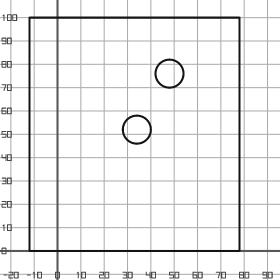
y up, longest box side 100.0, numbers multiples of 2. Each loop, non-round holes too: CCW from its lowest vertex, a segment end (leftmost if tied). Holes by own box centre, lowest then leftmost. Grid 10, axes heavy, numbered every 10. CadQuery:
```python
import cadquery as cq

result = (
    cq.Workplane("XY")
    .moveTo(-12.0, 0.0)
    .lineTo(78.0, 0.0)
    .lineTo(78.0, 100.0)
    .lineTo(-12.0, 100.0)
    .close()
    .moveTo(34.0, 52.0)
    .circle(6.0)
    .moveTo(48.0, 76.0)
    .circle(6.0)
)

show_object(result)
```